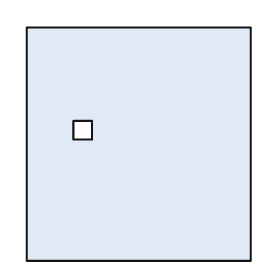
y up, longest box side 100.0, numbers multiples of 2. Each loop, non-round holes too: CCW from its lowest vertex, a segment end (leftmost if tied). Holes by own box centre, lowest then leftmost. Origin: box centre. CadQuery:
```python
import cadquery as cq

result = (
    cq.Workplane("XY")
    .moveTo(-48.0, -50.0)
    .lineTo(48.0, -50.0)
    .lineTo(48.0, 50.0)
    .lineTo(-48.0, 50.0)
    .close()
    .moveTo(-28.0, 2.0)
    .lineTo(-20.0, 2.0)
    .lineTo(-20.0, 10.0)
    .lineTo(-28.0, 10.0)
    .close()
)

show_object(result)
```